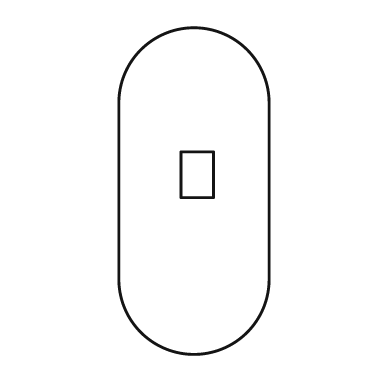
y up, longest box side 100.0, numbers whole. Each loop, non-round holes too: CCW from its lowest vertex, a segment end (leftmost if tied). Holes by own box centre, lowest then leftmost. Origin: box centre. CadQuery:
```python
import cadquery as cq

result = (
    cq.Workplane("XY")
    .moveTo(-23.0, -27.0)
    .threePointArc((0.0, -50.0), (23.0, -27.0))
    .lineTo(23.0, 27.0)
    .threePointArc((0.0, 50.0), (-23.0, 27.0))
    .close()
    .moveTo(-4.0, -2.0)
    .lineTo(6.0, -2.0)
    .lineTo(6.0, 12.0)
    .lineTo(-4.0, 12.0)
    .close()
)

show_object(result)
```